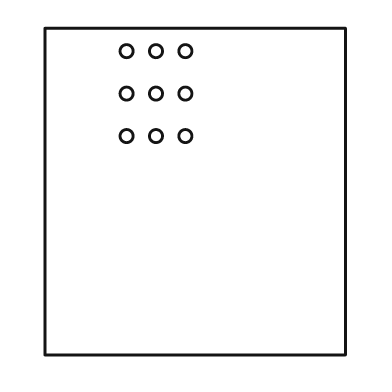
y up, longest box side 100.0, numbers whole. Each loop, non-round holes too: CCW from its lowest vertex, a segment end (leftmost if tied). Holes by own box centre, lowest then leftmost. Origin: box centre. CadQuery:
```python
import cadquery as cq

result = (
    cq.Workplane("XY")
    .moveTo(-46.0, -50.0)
    .lineTo(46.0, -50.0)
    .lineTo(46.0, 50.0)
    .lineTo(-46.0, 50.0)
    .close()
    .moveTo(-21.0, 17.0)
    .circle(2.0)
    .moveTo(-12.0, 17.0)
    .circle(2.0)
    .moveTo(-3.0, 17.0)
    .circle(2.0)
    .moveTo(-21.0, 30.0)
    .circle(2.0)
    .moveTo(-12.0, 30.0)
    .circle(2.0)
    .moveTo(-3.0, 30.0)
    .circle(2.0)
    .moveTo(-21.0, 43.0)
    .circle(2.0)
    .moveTo(-12.0, 43.0)
    .circle(2.0)
    .moveTo(-3.0, 43.0)
    .circle(2.0)
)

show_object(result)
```